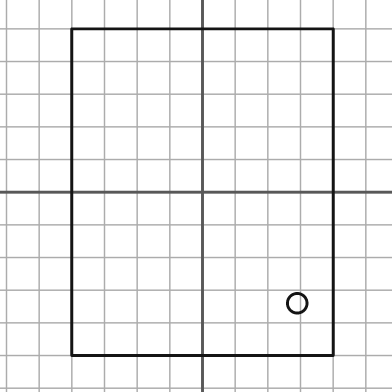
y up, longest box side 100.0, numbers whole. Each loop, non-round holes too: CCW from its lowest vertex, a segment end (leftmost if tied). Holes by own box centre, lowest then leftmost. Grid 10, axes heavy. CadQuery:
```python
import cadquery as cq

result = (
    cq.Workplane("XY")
    .moveTo(-40.0, -50.0)
    .lineTo(40.0, -50.0)
    .lineTo(40.0, 50.0)
    .lineTo(-40.0, 50.0)
    .close()
    .moveTo(29.0, -34.0)
    .circle(3.0)
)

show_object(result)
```